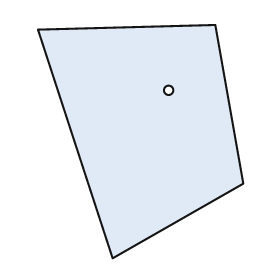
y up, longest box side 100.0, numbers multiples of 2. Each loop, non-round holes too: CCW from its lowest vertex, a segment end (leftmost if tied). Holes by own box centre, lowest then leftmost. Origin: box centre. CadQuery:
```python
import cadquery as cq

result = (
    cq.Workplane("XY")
    .moveTo(-12.0, -50.0)
    .lineTo(44.0, -18.0)
    .lineTo(32.0, 50.0)
    .lineTo(-44.0, 48.0)
    .close()
    .moveTo(12.0, 22.0)
    .circle(2.0)
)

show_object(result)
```